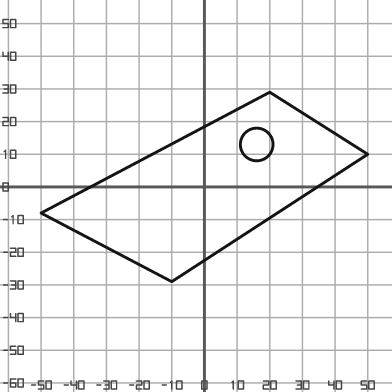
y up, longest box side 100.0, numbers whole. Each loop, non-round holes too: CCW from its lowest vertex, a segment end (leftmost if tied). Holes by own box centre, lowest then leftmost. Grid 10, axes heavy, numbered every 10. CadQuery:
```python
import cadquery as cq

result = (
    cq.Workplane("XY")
    .moveTo(-10.0, -29.0)
    .lineTo(50.0, 10.0)
    .lineTo(20.0, 29.0)
    .lineTo(-50.0, -8.0)
    .close()
    .moveTo(16.0, 13.0)
    .circle(5.0)
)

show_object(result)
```